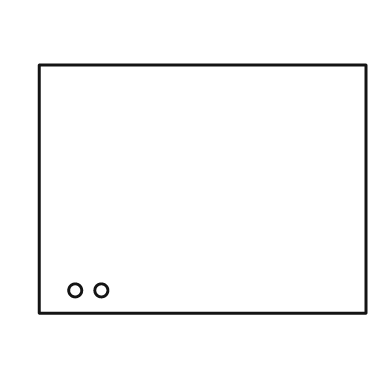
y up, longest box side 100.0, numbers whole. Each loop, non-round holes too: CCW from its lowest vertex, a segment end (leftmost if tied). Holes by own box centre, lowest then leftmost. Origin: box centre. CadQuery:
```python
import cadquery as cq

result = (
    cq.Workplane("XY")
    .moveTo(-50.0, -38.0)
    .lineTo(50.0, -38.0)
    .lineTo(50.0, 38.0)
    .lineTo(-50.0, 38.0)
    .close()
    .moveTo(-39.0, -31.0)
    .circle(2.0)
    .moveTo(-31.0, -31.0)
    .circle(2.0)
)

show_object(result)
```